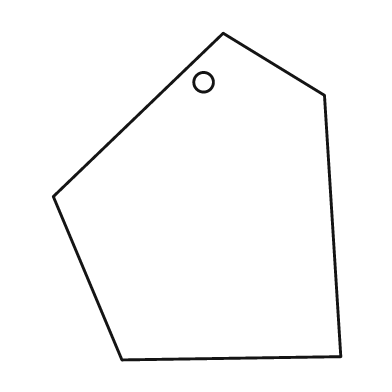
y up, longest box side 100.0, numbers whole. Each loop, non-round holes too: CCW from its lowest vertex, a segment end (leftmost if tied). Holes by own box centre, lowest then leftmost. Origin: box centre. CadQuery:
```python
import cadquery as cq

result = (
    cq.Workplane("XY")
    .moveTo(-23.0, -50.0)
    .lineTo(44.0, -49.0)
    .lineTo(39.0, 31.0)
    .lineTo(8.0, 50.0)
    .lineTo(-44.0, 0.0)
    .close()
    .moveTo(2.0, 35.0)
    .circle(3.0)
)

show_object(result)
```